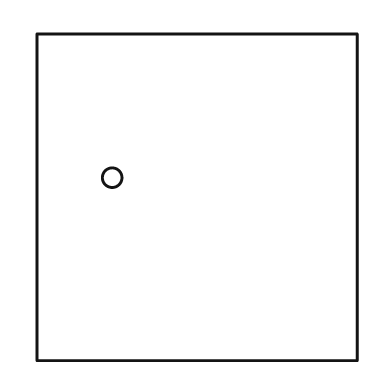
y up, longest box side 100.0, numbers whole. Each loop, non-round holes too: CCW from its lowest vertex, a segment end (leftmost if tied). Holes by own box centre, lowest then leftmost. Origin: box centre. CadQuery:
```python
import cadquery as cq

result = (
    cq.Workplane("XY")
    .moveTo(-49.0, -50.0)
    .lineTo(49.0, -50.0)
    .lineTo(49.0, 50.0)
    .lineTo(-49.0, 50.0)
    .close()
    .moveTo(-26.0, 6.0)
    .circle(3.0)
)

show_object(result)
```